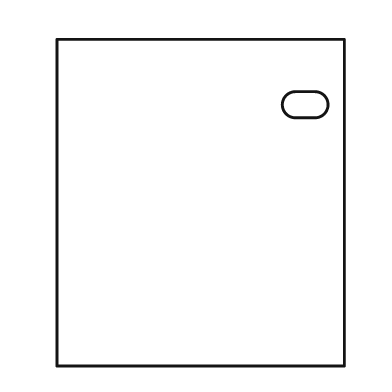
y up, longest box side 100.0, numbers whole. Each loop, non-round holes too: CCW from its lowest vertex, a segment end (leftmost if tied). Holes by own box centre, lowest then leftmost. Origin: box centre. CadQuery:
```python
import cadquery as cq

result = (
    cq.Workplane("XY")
    .moveTo(-44.0, -50.0)
    .lineTo(44.0, -50.0)
    .lineTo(44.0, 50.0)
    .lineTo(-44.0, 50.0)
    .close()
    .moveTo(29.0, 26.0)
    .lineTo(35.0, 26.0)
    .threePointArc((39.0, 30.0), (35.0, 34.0))
    .lineTo(29.0, 34.0)
    .threePointArc((25.0, 30.0), (29.0, 26.0))
    .close()
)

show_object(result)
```